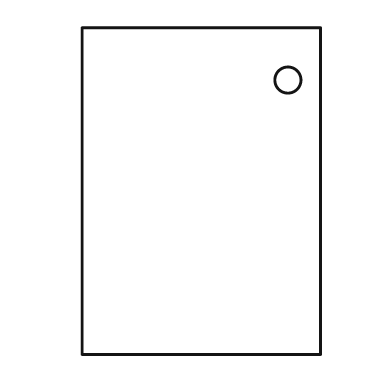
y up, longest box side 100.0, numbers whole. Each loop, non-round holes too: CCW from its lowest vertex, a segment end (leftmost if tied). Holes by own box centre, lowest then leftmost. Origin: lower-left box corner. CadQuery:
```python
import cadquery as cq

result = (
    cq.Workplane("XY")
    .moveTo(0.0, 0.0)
    .lineTo(73.0, 0.0)
    .lineTo(73.0, 100.0)
    .lineTo(0.0, 100.0)
    .close()
    .moveTo(63.0, 84.0)
    .circle(4.0)
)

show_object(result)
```